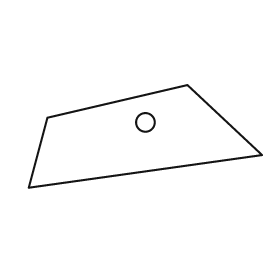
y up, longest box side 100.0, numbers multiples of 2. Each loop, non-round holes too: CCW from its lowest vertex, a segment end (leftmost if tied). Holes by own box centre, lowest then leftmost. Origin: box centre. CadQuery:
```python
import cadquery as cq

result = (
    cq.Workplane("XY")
    .moveTo(-50.0, -22.0)
    .lineTo(50.0, -8.0)
    .lineTo(18.0, 22.0)
    .lineTo(-42.0, 8.0)
    .close()
    .moveTo(0.0, 6.0)
    .circle(4.0)
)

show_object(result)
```